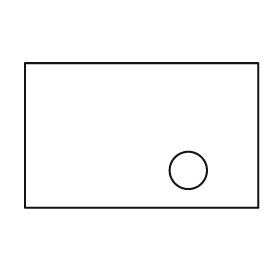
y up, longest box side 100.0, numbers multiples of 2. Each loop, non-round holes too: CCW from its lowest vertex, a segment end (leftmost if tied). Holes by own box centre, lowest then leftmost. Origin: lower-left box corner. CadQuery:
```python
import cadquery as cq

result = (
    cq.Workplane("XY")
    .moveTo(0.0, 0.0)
    .lineTo(100.0, 0.0)
    .lineTo(100.0, 62.0)
    .lineTo(0.0, 62.0)
    .close()
    .moveTo(70.0, 16.0)
    .circle(8.0)
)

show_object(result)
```